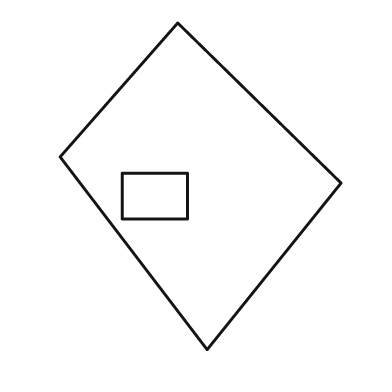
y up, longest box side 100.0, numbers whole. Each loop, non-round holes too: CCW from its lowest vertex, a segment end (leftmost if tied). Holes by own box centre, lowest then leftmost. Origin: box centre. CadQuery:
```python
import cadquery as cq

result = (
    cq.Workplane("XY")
    .moveTo(2.0, -50.0)
    .lineTo(43.0, 1.0)
    .lineTo(-7.0, 50.0)
    .lineTo(-43.0, 9.0)
    .close()
    .moveTo(-24.0, -10.0)
    .lineTo(-4.0, -10.0)
    .lineTo(-4.0, 4.0)
    .lineTo(-24.0, 4.0)
    .close()
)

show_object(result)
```